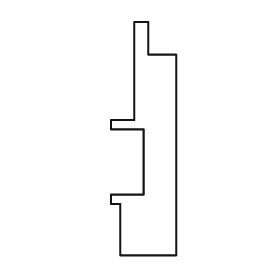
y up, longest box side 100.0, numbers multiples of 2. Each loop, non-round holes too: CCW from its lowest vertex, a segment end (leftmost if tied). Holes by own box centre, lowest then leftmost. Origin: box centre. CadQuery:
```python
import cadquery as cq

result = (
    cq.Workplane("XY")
    .moveTo(-10.0, -50.0)
    .lineTo(14.0, -50.0)
    .lineTo(14.0, 36.0)
    .lineTo(2.0, 36.0)
    .lineTo(2.0, 50.0)
    .lineTo(-4.0, 50.0)
    .lineTo(-4.0, 8.0)
    .lineTo(-14.0, 8.0)
    .lineTo(-14.0, 4.0)
    .lineTo(0.0, 4.0)
    .lineTo(0.0, -24.0)
    .lineTo(-14.0, -24.0)
    .lineTo(-14.0, -28.0)
    .lineTo(-10.0, -28.0)
    .close()
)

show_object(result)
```